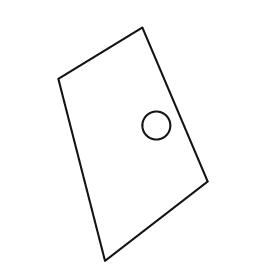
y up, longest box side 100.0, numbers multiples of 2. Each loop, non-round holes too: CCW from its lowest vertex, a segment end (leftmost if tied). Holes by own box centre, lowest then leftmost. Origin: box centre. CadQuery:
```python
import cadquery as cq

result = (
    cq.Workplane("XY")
    .moveTo(-12.0, -50.0)
    .lineTo(32.0, -16.0)
    .lineTo(4.0, 50.0)
    .lineTo(-32.0, 28.0)
    .close()
    .moveTo(10.0, 8.0)
    .circle(6.0)
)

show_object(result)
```